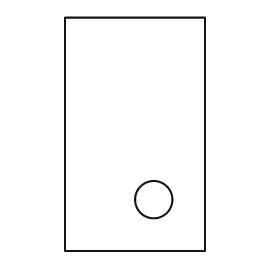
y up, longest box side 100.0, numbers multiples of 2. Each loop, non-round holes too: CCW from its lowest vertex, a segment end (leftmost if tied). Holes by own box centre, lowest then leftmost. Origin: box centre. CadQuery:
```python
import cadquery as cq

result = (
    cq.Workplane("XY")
    .moveTo(-30.0, -50.0)
    .lineTo(30.0, -50.0)
    .lineTo(30.0, 50.0)
    .lineTo(-30.0, 50.0)
    .close()
    .moveTo(8.0, -28.0)
    .circle(8.0)
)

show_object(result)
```